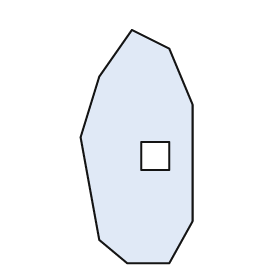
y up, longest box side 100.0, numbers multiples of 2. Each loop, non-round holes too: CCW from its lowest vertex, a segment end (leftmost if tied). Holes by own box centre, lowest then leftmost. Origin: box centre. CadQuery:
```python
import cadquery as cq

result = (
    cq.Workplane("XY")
    .moveTo(-4.0, -50.0)
    .lineTo(14.0, -50.0)
    .lineTo(24.0, -32.0)
    .lineTo(24.0, 18.0)
    .lineTo(14.0, 42.0)
    .lineTo(-2.0, 50.0)
    .lineTo(-16.0, 30.0)
    .lineTo(-24.0, 4.0)
    .lineTo(-16.0, -40.0)
    .close()
    .moveTo(2.0, -10.0)
    .lineTo(14.0, -10.0)
    .lineTo(14.0, 2.0)
    .lineTo(2.0, 2.0)
    .close()
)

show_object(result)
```